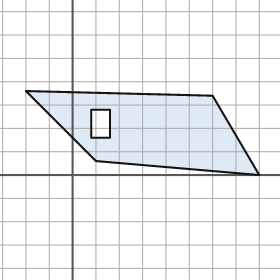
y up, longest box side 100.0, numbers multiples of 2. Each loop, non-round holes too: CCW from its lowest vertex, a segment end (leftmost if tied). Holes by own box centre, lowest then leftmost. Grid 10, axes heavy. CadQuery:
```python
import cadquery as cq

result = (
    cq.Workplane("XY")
    .moveTo(80.0, 0.0)
    .lineTo(60.0, 34.0)
    .lineTo(-20.0, 36.0)
    .lineTo(10.0, 6.0)
    .close()
    .moveTo(8.0, 16.0)
    .lineTo(16.0, 16.0)
    .lineTo(16.0, 28.0)
    .lineTo(8.0, 28.0)
    .close()
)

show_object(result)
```